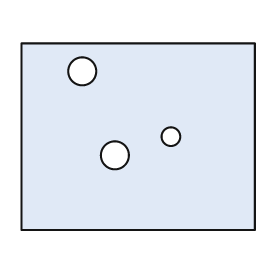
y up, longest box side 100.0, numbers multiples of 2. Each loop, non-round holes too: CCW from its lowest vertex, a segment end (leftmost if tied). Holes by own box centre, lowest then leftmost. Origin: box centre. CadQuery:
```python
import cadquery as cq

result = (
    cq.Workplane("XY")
    .moveTo(-50.0, -40.0)
    .lineTo(50.0, -40.0)
    .lineTo(50.0, 40.0)
    .lineTo(-50.0, 40.0)
    .close()
    .moveTo(-10.0, -8.0)
    .circle(6.0)
    .moveTo(14.0, 0.0)
    .circle(4.0)
    .moveTo(-24.0, 28.0)
    .circle(6.0)
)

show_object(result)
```